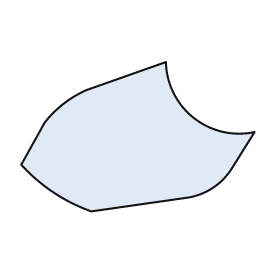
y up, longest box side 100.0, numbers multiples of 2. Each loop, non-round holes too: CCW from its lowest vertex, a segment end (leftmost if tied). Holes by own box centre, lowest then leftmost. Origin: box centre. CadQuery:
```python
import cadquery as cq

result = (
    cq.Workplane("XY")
    .moveTo(-20.0, -32.0)
    .lineTo(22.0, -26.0)
    .threePointArc((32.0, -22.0), (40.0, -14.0))
    .lineTo(50.0, 2.0)
    .threePointArc((24.0, 8.0), (12.0, 32.0))
    .lineTo(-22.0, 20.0)
    .threePointArc((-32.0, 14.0), (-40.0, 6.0))
    .lineTo(-50.0, -12.0)
    .threePointArc((-36.0, -24.0), (-20.0, -32.0))
    .close()
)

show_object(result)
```